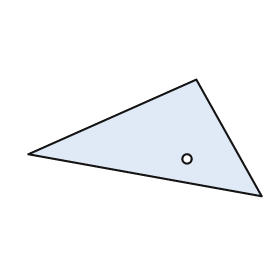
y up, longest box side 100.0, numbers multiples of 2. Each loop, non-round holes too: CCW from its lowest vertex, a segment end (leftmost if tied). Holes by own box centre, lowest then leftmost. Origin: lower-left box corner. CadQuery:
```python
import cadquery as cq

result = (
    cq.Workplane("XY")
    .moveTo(100.0, 0.0)
    .lineTo(72.0, 50.0)
    .lineTo(0.0, 18.0)
    .close()
    .moveTo(68.0, 16.0)
    .circle(2.0)
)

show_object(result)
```